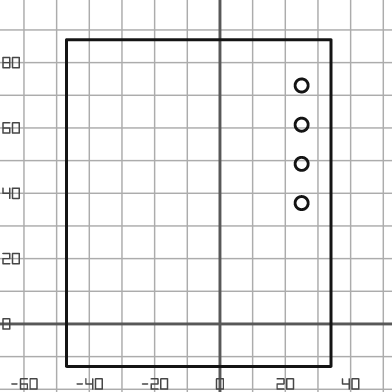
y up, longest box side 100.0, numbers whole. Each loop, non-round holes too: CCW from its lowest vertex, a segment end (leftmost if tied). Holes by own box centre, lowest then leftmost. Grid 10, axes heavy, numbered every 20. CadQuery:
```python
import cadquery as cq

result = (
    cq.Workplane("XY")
    .moveTo(-47.0, -13.0)
    .lineTo(34.0, -13.0)
    .lineTo(34.0, 87.0)
    .lineTo(-47.0, 87.0)
    .close()
    .moveTo(25.0, 37.0)
    .circle(2.0)
    .moveTo(25.0, 49.0)
    .circle(2.0)
    .moveTo(25.0, 61.0)
    .circle(2.0)
    .moveTo(25.0, 73.0)
    .circle(2.0)
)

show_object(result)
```